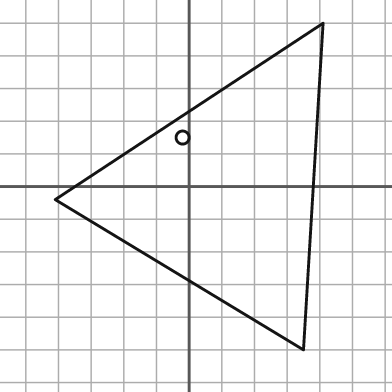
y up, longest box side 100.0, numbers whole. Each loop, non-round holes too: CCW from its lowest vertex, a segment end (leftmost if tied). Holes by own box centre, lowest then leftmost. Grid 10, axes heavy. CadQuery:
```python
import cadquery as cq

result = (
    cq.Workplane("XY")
    .moveTo(35.0, -50.0)
    .lineTo(41.0, 50.0)
    .lineTo(-41.0, -4.0)
    .close()
    .moveTo(-2.0, 15.0)
    .circle(2.0)
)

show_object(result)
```